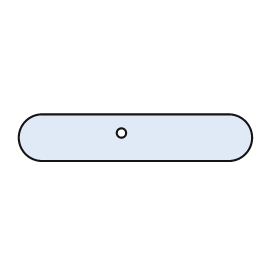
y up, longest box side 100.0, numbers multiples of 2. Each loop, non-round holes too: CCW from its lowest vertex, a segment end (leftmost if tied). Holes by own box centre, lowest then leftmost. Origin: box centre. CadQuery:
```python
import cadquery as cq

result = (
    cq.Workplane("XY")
    .moveTo(-40.0, -10.0)
    .lineTo(40.0, -10.0)
    .threePointArc((50.0, 0.0), (40.0, 10.0))
    .lineTo(-40.0, 10.0)
    .threePointArc((-50.0, 0.0), (-40.0, -10.0))
    .close()
    .moveTo(-6.0, 2.0)
    .circle(2.0)
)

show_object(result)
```